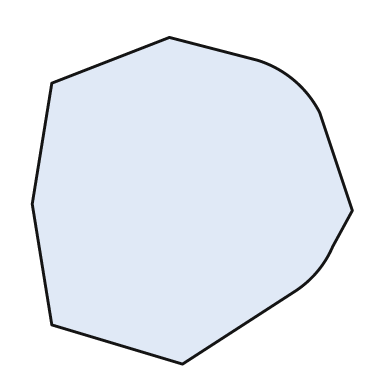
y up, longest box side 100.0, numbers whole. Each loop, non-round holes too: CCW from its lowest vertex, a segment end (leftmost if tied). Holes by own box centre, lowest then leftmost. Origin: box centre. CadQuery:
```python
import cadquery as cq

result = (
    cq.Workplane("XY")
    .moveTo(-3.0, -50.0)
    .lineTo(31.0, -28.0)
    .threePointArc((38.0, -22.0), (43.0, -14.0))
    .lineTo(49.0, -3.0)
    .lineTo(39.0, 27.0)
    .threePointArc((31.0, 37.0), (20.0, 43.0))
    .lineTo(-7.0, 50.0)
    .lineTo(-43.0, 36.0)
    .lineTo(-49.0, -1.0)
    .lineTo(-43.0, -38.0)
    .close()
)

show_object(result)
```